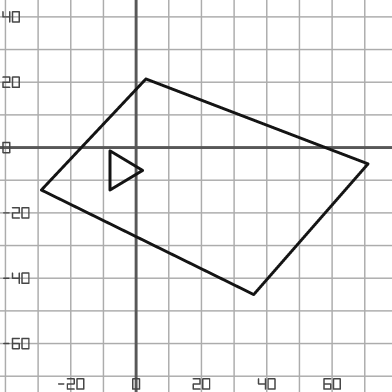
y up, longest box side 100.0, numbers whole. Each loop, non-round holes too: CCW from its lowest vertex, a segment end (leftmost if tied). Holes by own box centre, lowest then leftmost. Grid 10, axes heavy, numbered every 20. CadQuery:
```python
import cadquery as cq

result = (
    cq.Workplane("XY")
    .moveTo(36.0, -45.0)
    .lineTo(71.0, -5.0)
    .lineTo(3.0, 21.0)
    .lineTo(-29.0, -13.0)
    .close()
    .moveTo(-8.0, -13.0)
    .lineTo(2.0, -7.0)
    .lineTo(-8.0, -1.0)
    .close()
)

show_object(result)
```